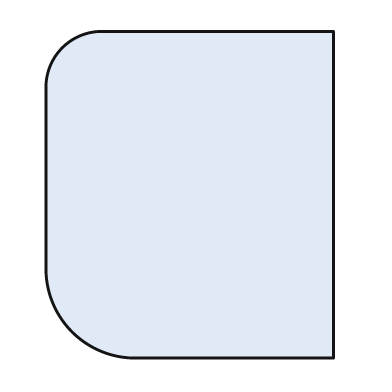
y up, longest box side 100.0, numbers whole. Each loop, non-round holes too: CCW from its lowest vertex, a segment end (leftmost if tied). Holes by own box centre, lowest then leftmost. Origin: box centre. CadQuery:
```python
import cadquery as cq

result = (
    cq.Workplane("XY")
    .moveTo(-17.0, -50.0)
    .lineTo(44.0, -50.0)
    .lineTo(44.0, 50.0)
    .lineTo(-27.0, 50.0)
    .threePointArc((-39.0, 45.0), (-44.0, 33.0))
    .lineTo(-44.0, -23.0)
    .threePointArc((-36.0, -42.0), (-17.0, -50.0))
    .close()
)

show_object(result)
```